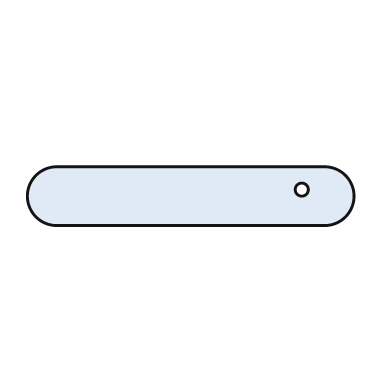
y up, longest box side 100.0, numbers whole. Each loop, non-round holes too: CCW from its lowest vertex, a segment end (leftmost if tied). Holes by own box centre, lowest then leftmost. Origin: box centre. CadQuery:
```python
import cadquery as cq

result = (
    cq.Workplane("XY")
    .moveTo(-41.0, -9.0)
    .lineTo(41.0, -9.0)
    .threePointArc((50.0, 0.0), (41.0, 9.0))
    .lineTo(-41.0, 9.0)
    .threePointArc((-50.0, 0.0), (-41.0, -9.0))
    .close()
    .moveTo(34.0, 2.0)
    .circle(2.0)
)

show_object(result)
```